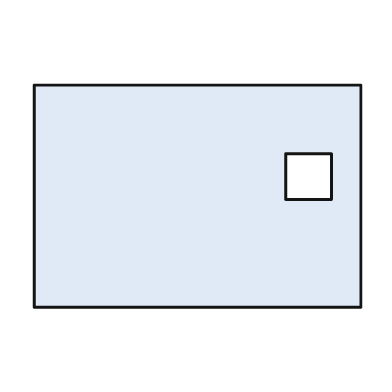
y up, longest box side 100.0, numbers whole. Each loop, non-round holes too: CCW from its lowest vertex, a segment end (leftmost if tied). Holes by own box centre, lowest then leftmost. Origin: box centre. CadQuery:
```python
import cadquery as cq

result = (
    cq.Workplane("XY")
    .moveTo(-50.0, -34.0)
    .lineTo(50.0, -34.0)
    .lineTo(50.0, 34.0)
    .lineTo(-50.0, 34.0)
    .close()
    .moveTo(27.0, -1.0)
    .lineTo(41.0, -1.0)
    .lineTo(41.0, 13.0)
    .lineTo(27.0, 13.0)
    .close()
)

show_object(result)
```